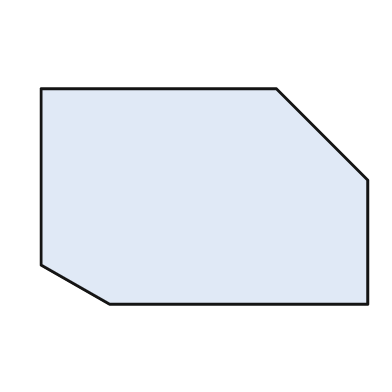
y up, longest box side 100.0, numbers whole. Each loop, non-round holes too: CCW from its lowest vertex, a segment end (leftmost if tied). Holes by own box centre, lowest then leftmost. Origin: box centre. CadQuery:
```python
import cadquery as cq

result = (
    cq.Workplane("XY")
    .moveTo(-29.0, -33.0)
    .lineTo(50.0, -33.0)
    .lineTo(50.0, 5.0)
    .lineTo(22.0, 33.0)
    .lineTo(-50.0, 33.0)
    .lineTo(-50.0, -21.0)
    .close()
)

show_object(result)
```